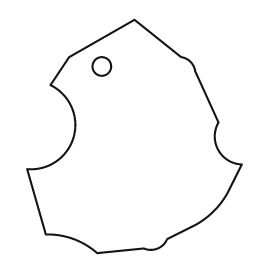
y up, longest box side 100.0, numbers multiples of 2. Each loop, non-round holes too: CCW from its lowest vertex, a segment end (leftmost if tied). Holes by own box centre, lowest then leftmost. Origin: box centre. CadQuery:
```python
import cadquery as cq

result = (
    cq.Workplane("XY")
    .moveTo(-16.0, -50.0)
    .lineTo(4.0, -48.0)
    .threePointArc((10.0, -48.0), (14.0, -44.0))
    .lineTo(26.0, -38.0)
    .threePointArc((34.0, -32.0), (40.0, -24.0))
    .lineTo(46.0, -12.0)
    .threePointArc((36.0, -6.0), (36.0, 6.0))
    .lineTo(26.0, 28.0)
    .threePointArc((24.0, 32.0), (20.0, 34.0))
    .lineTo(0.0, 50.0)
    .lineTo(-28.0, 34.0)
    .lineTo(-36.0, 22.0)
    .threePointArc((-26.0, 0.0), (-46.0, -14.0))
    .lineTo(-38.0, -42.0)
    .threePointArc((-26.0, -44.0), (-16.0, -50.0))
    .close()
    .moveTo(-14.0, 30.0)
    .circle(4.0)
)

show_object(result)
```